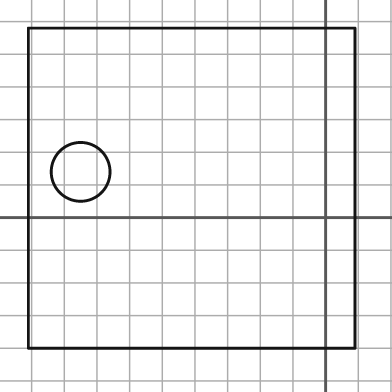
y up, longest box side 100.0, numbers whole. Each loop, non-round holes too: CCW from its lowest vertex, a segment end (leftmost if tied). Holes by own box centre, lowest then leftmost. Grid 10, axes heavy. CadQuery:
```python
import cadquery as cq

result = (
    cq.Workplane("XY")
    .moveTo(-91.0, -40.0)
    .lineTo(9.0, -40.0)
    .lineTo(9.0, 58.0)
    .lineTo(-91.0, 58.0)
    .close()
    .moveTo(-75.0, 14.0)
    .circle(9.0)
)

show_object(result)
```